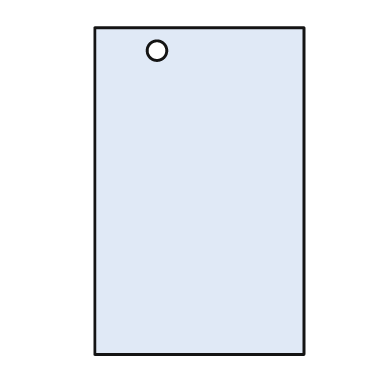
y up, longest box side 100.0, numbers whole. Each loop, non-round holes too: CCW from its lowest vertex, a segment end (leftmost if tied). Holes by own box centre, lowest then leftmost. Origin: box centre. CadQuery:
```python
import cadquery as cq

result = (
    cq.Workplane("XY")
    .moveTo(-32.0, -50.0)
    .lineTo(32.0, -50.0)
    .lineTo(32.0, 50.0)
    .lineTo(-32.0, 50.0)
    .close()
    .moveTo(-13.0, 43.0)
    .circle(3.0)
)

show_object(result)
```